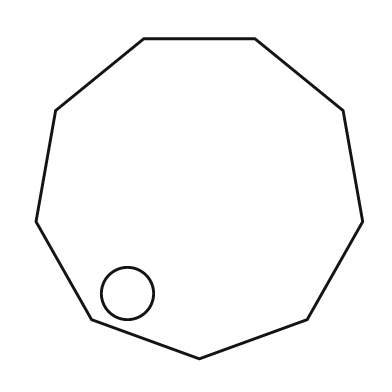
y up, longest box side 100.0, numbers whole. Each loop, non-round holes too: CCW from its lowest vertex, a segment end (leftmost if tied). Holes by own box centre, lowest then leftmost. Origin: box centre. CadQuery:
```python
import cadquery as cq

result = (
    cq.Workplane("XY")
    .moveTo(0.0, -49.0)
    .lineTo(33.0, -37.0)
    .lineTo(50.0, -7.0)
    .lineTo(44.0, 27.0)
    .lineTo(17.0, 49.0)
    .lineTo(-17.0, 49.0)
    .lineTo(-44.0, 27.0)
    .lineTo(-50.0, -7.0)
    .lineTo(-33.0, -37.0)
    .close()
    .moveTo(-22.0, -29.0)
    .circle(8.0)
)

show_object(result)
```